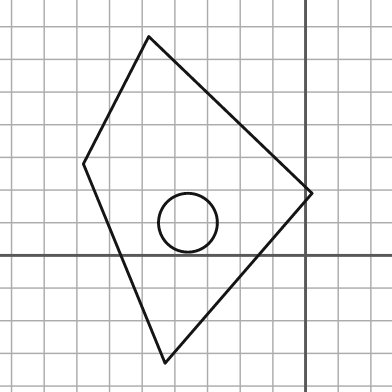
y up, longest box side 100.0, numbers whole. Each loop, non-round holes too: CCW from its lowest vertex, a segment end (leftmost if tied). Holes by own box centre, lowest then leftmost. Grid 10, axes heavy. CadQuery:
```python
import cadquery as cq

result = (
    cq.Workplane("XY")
    .moveTo(-43.0, -33.0)
    .lineTo(2.0, 19.0)
    .lineTo(-48.0, 67.0)
    .lineTo(-68.0, 28.0)
    .close()
    .moveTo(-36.0, 10.0)
    .circle(9.0)
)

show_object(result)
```